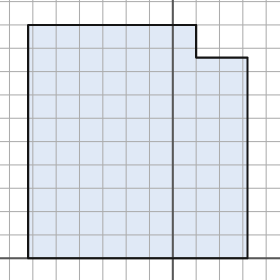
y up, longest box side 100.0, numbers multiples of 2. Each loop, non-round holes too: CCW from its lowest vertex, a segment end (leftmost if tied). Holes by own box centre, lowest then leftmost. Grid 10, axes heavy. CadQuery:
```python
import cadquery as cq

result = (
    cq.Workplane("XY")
    .moveTo(-62.0, 0.0)
    .lineTo(32.0, 0.0)
    .lineTo(32.0, 86.0)
    .lineTo(10.0, 86.0)
    .lineTo(10.0, 100.0)
    .lineTo(-62.0, 100.0)
    .close()
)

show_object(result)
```